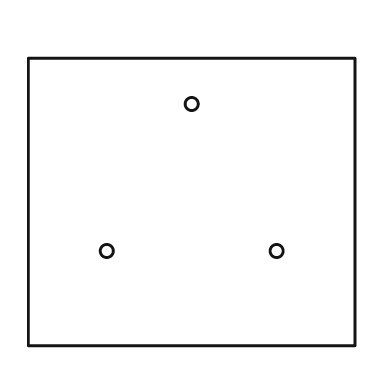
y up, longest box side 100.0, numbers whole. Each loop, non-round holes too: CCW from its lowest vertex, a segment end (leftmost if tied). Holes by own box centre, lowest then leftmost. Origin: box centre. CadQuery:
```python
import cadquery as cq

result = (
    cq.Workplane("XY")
    .moveTo(-50.0, -44.0)
    .lineTo(50.0, -44.0)
    .lineTo(50.0, 44.0)
    .lineTo(-50.0, 44.0)
    .close()
    .moveTo(-26.0, -15.0)
    .circle(2.0)
    .moveTo(26.0, -15.0)
    .circle(2.0)
    .moveTo(0.0, 30.0)
    .circle(2.0)
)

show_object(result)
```